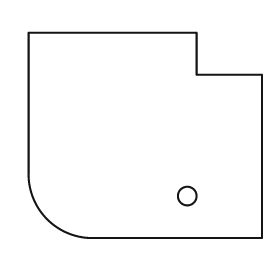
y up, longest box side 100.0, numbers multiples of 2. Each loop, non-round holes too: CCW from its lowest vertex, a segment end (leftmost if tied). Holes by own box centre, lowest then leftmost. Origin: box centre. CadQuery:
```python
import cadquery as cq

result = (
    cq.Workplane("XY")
    .moveTo(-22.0, -44.0)
    .lineTo(50.0, -44.0)
    .lineTo(50.0, 26.0)
    .lineTo(22.0, 26.0)
    .lineTo(22.0, 44.0)
    .lineTo(-50.0, 44.0)
    .lineTo(-50.0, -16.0)
    .threePointArc((-42.0, -36.0), (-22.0, -44.0))
    .close()
    .moveTo(18.0, -26.0)
    .circle(4.0)
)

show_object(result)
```